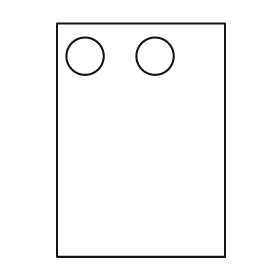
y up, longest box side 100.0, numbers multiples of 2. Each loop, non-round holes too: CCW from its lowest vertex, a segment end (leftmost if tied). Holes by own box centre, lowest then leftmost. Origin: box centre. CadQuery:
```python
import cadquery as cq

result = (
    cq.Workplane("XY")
    .moveTo(-36.0, -50.0)
    .lineTo(36.0, -50.0)
    .lineTo(36.0, 50.0)
    .lineTo(-36.0, 50.0)
    .close()
    .moveTo(-24.0, 36.0)
    .circle(8.0)
    .moveTo(6.0, 36.0)
    .circle(8.0)
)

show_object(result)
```